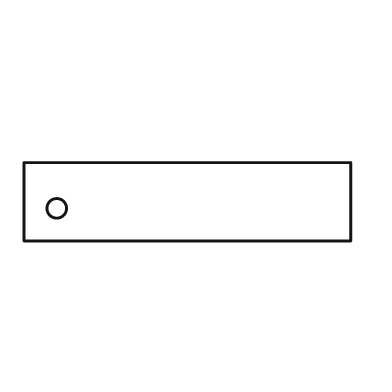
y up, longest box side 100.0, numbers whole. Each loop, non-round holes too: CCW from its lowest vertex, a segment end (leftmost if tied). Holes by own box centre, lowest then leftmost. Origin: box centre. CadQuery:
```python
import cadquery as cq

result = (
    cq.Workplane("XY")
    .moveTo(-50.0, -12.0)
    .lineTo(50.0, -12.0)
    .lineTo(50.0, 12.0)
    .lineTo(-50.0, 12.0)
    .close()
    .moveTo(-40.0, -2.0)
    .circle(3.0)
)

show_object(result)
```